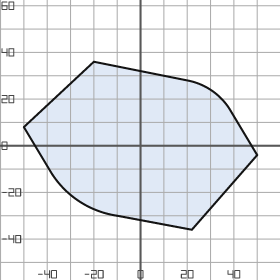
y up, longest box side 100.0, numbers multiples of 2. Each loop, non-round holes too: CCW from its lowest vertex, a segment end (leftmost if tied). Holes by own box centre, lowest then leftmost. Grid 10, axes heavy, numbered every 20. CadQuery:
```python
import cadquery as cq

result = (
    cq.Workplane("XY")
    .moveTo(22.0, -36.0)
    .lineTo(50.0, -4.0)
    .lineTo(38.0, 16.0)
    .threePointArc((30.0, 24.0), (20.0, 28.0))
    .lineTo(-20.0, 36.0)
    .lineTo(-50.0, 8.0)
    .lineTo(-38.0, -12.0)
    .threePointArc((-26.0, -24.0), (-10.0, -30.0))
    .close()
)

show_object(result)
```